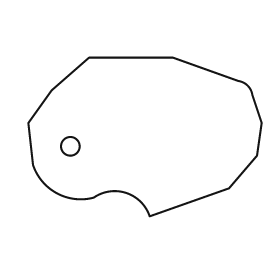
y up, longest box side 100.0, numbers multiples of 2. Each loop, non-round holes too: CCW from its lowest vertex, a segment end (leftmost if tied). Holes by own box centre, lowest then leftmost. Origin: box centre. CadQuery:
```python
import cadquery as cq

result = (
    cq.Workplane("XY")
    .moveTo(2.0, -34.0)
    .lineTo(36.0, -22.0)
    .lineTo(48.0, -8.0)
    .lineTo(50.0, 6.0)
    .lineTo(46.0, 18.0)
    .threePointArc((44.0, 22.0), (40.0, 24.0))
    .lineTo(12.0, 34.0)
    .lineTo(-24.0, 34.0)
    .lineTo(-40.0, 20.0)
    .lineTo(-50.0, 6.0)
    .lineTo(-48.0, -12.0)
    .threePointArc((-38.0, -24.0), (-22.0, -26.0))
    .threePointArc((-8.0, -24.0), (2.0, -34.0))
    .close()
    .moveTo(-32.0, -4.0)
    .circle(4.0)
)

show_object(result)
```